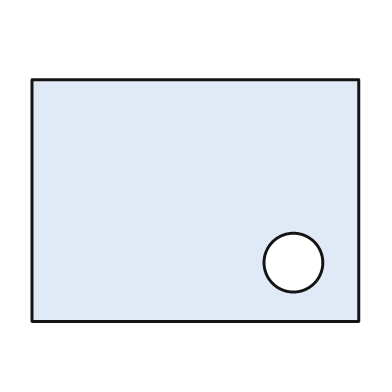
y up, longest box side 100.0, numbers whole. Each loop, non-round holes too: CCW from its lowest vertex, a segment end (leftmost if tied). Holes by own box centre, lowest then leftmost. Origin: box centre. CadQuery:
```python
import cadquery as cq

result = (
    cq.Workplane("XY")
    .moveTo(-50.0, -37.0)
    .lineTo(50.0, -37.0)
    .lineTo(50.0, 37.0)
    .lineTo(-50.0, 37.0)
    .close()
    .moveTo(30.0, -19.0)
    .circle(9.0)
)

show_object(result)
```